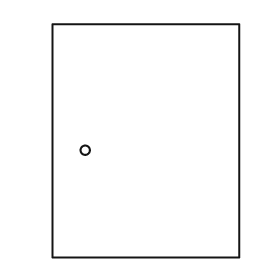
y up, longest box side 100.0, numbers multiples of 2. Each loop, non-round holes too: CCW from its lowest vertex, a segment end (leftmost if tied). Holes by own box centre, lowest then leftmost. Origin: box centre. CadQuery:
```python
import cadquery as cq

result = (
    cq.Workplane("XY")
    .moveTo(-40.0, -50.0)
    .lineTo(40.0, -50.0)
    .lineTo(40.0, 50.0)
    .lineTo(-40.0, 50.0)
    .close()
    .moveTo(-26.0, -4.0)
    .circle(2.0)
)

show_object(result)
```